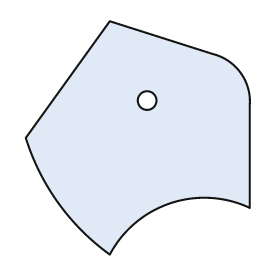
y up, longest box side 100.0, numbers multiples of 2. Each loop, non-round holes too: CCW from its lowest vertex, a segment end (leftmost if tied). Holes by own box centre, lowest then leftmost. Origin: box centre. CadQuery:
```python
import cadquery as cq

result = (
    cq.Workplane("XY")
    .moveTo(-12.0, -50.0)
    .threePointArc((14.0, -28.0), (48.0, -30.0))
    .lineTo(48.0, 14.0)
    .threePointArc((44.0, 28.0), (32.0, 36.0))
    .lineTo(-12.0, 50.0)
    .lineTo(-48.0, 0.0)
    .threePointArc((-34.0, -28.0), (-12.0, -50.0))
    .close()
    .moveTo(4.0, 16.0)
    .circle(4.0)
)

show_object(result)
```